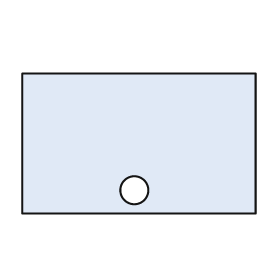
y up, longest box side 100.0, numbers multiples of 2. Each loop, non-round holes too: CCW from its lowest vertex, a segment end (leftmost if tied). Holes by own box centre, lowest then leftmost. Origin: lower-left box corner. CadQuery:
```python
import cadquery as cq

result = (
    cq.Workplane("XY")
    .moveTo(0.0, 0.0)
    .lineTo(100.0, 0.0)
    .lineTo(100.0, 60.0)
    .lineTo(0.0, 60.0)
    .close()
    .moveTo(48.0, 10.0)
    .circle(6.0)
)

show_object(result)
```